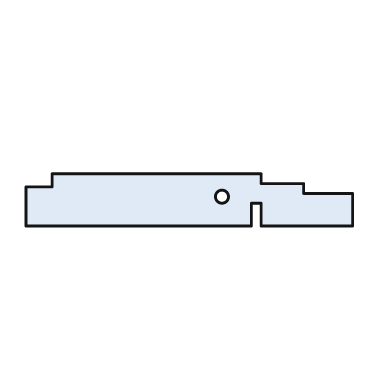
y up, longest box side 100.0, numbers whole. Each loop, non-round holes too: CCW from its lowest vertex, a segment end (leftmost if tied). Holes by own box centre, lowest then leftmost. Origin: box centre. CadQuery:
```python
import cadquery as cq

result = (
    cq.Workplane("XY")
    .moveTo(-50.0, -8.0)
    .lineTo(19.0, -8.0)
    .lineTo(19.0, -1.0)
    .lineTo(22.0, -1.0)
    .lineTo(22.0, -8.0)
    .lineTo(50.0, -8.0)
    .lineTo(50.0, 2.0)
    .lineTo(35.0, 2.0)
    .lineTo(35.0, 5.0)
    .lineTo(22.0, 5.0)
    .lineTo(22.0, 8.0)
    .lineTo(-42.0, 8.0)
    .lineTo(-42.0, 4.0)
    .lineTo(-50.0, 4.0)
    .close()
    .moveTo(10.0, 1.0)
    .circle(2.0)
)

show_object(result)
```